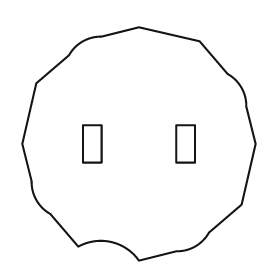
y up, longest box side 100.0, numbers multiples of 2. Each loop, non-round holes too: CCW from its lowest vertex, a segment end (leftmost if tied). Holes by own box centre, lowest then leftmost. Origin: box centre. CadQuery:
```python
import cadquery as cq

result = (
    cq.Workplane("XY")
    .moveTo(0.0, -50.0)
    .lineTo(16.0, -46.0)
    .threePointArc((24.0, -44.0), (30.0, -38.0))
    .lineTo(44.0, -26.0)
    .lineTo(50.0, 0.0)
    .lineTo(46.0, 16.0)
    .threePointArc((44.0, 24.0), (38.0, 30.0))
    .lineTo(26.0, 44.0)
    .lineTo(0.0, 50.0)
    .lineTo(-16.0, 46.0)
    .threePointArc((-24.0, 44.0), (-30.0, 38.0))
    .lineTo(-44.0, 26.0)
    .lineTo(-50.0, 0.0)
    .lineTo(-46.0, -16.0)
    .threePointArc((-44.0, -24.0), (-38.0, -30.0))
    .lineTo(-26.0, -44.0)
    .threePointArc((-12.0, -42.0), (0.0, -50.0))
    .close()
    .moveTo(-24.0, -8.0)
    .lineTo(-16.0, -8.0)
    .lineTo(-16.0, 8.0)
    .lineTo(-24.0, 8.0)
    .close()
    .moveTo(16.0, -8.0)
    .lineTo(24.0, -8.0)
    .lineTo(24.0, 8.0)
    .lineTo(16.0, 8.0)
    .close()
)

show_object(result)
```